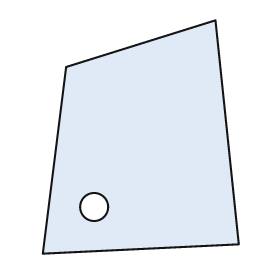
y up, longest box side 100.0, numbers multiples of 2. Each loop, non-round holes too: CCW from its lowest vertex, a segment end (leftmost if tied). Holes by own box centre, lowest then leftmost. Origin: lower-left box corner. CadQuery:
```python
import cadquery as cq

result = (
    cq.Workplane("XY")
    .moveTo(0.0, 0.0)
    .lineTo(84.0, 4.0)
    .lineTo(74.0, 100.0)
    .lineTo(10.0, 80.0)
    .close()
    .moveTo(22.0, 20.0)
    .circle(6.0)
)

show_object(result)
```